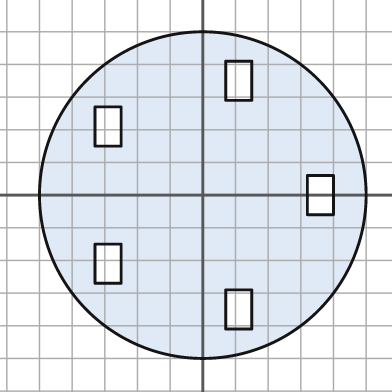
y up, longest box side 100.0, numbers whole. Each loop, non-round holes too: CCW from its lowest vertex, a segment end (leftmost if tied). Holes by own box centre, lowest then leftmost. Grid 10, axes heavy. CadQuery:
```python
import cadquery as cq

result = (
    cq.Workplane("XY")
    .moveTo(0.0, 0.0)
    .circle(50.0)
    .moveTo(7.0, -41.0)
    .lineTo(15.0, -41.0)
    .lineTo(15.0, -29.0)
    .lineTo(7.0, -29.0)
    .close()
    .moveTo(-33.0, -27.0)
    .lineTo(-25.0, -27.0)
    .lineTo(-25.0, -15.0)
    .lineTo(-33.0, -15.0)
    .close()
    .moveTo(32.0, -6.0)
    .lineTo(40.0, -6.0)
    .lineTo(40.0, 6.0)
    .lineTo(32.0, 6.0)
    .close()
    .moveTo(-33.0, 15.0)
    .lineTo(-25.0, 15.0)
    .lineTo(-25.0, 27.0)
    .lineTo(-33.0, 27.0)
    .close()
    .moveTo(7.0, 29.0)
    .lineTo(15.0, 29.0)
    .lineTo(15.0, 41.0)
    .lineTo(7.0, 41.0)
    .close()
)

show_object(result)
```